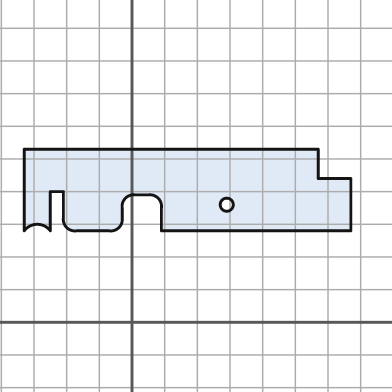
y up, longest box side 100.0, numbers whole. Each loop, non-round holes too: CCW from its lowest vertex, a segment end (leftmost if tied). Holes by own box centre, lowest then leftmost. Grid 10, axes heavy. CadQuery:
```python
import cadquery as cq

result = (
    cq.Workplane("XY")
    .moveTo(-33.0, 28.0)
    .threePointArc((-29.0, 30.0), (-25.0, 28.0))
    .lineTo(-25.0, 40.0)
    .lineTo(-21.0, 40.0)
    .lineTo(-21.0, 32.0)
    .threePointArc((-20.0, 29.0), (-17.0, 28.0))
    .lineTo(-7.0, 28.0)
    .threePointArc((-4.0, 29.0), (-3.0, 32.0))
    .lineTo(-3.0, 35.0)
    .threePointArc((-2.0, 38.0), (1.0, 39.0))
    .lineTo(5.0, 39.0)
    .threePointArc((8.0, 38.0), (9.0, 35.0))
    .lineTo(9.0, 28.0)
    .lineTo(67.0, 28.0)
    .lineTo(67.0, 44.0)
    .lineTo(57.0, 44.0)
    .lineTo(57.0, 53.0)
    .lineTo(-33.0, 53.0)
    .close()
    .moveTo(29.0, 36.0)
    .circle(2.0)
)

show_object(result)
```